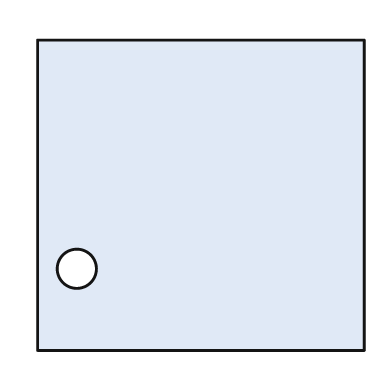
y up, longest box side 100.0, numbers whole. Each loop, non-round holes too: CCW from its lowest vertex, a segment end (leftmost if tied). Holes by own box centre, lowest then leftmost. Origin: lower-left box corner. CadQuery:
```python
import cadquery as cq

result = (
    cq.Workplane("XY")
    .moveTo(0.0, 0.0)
    .lineTo(100.0, 0.0)
    .lineTo(100.0, 95.0)
    .lineTo(0.0, 95.0)
    .close()
    .moveTo(12.0, 25.0)
    .circle(6.0)
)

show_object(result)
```